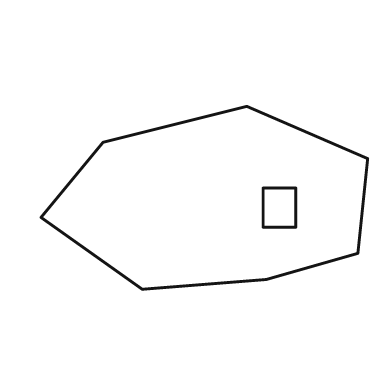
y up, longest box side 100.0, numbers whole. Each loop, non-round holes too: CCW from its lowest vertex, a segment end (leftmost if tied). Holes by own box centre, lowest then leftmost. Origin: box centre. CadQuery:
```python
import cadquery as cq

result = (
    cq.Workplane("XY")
    .moveTo(-19.0, -28.0)
    .lineTo(19.0, -25.0)
    .lineTo(47.0, -17.0)
    .lineTo(50.0, 12.0)
    .lineTo(13.0, 28.0)
    .lineTo(-31.0, 17.0)
    .lineTo(-50.0, -6.0)
    .close()
    .moveTo(18.0, -9.0)
    .lineTo(28.0, -9.0)
    .lineTo(28.0, 3.0)
    .lineTo(18.0, 3.0)
    .close()
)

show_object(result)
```